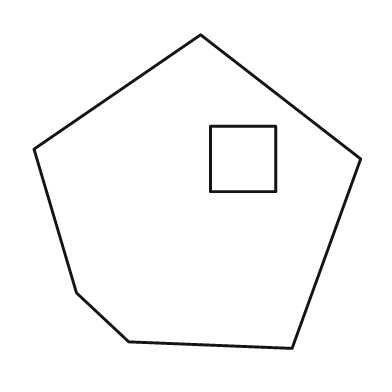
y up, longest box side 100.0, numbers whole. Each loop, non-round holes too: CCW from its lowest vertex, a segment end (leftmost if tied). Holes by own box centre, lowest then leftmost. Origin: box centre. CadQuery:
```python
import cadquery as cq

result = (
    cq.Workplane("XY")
    .moveTo(29.0, -48.0)
    .lineTo(50.0, 10.0)
    .lineTo(1.0, 48.0)
    .lineTo(-50.0, 13.0)
    .lineTo(-37.0, -31.0)
    .lineTo(-21.0, -46.0)
    .close()
    .moveTo(4.0, 0.0)
    .lineTo(24.0, 0.0)
    .lineTo(24.0, 20.0)
    .lineTo(4.0, 20.0)
    .close()
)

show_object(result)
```